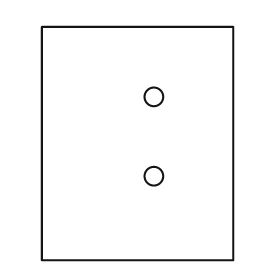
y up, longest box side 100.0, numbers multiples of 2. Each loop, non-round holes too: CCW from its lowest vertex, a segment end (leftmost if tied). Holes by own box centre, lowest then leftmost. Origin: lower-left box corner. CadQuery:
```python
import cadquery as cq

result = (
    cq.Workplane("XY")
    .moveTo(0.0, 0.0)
    .lineTo(82.0, 0.0)
    .lineTo(82.0, 100.0)
    .lineTo(0.0, 100.0)
    .close()
    .moveTo(48.0, 36.0)
    .circle(4.0)
    .moveTo(48.0, 70.0)
    .circle(4.0)
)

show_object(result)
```